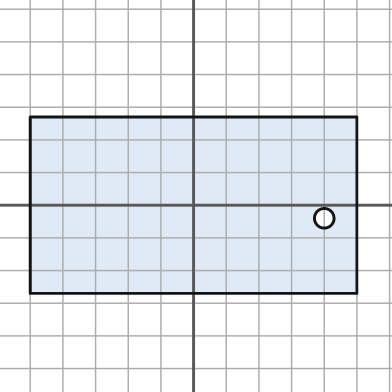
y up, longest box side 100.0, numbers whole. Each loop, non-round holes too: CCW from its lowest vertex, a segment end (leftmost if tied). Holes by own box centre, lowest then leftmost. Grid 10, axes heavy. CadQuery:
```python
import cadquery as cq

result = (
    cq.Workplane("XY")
    .moveTo(-50.0, -27.0)
    .lineTo(50.0, -27.0)
    .lineTo(50.0, 27.0)
    .lineTo(-50.0, 27.0)
    .close()
    .moveTo(40.0, -4.0)
    .circle(3.0)
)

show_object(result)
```